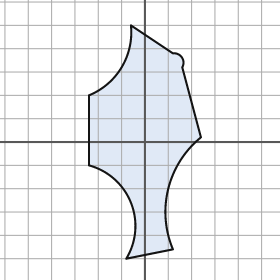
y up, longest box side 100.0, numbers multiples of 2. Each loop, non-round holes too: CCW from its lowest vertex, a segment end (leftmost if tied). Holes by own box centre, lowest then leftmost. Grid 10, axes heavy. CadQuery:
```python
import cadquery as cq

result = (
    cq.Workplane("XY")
    .moveTo(-8.0, -50.0)
    .lineTo(12.0, -46.0)
    .threePointArc((10.0, -20.0), (24.0, 2.0))
    .lineTo(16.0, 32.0)
    .threePointArc((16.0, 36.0), (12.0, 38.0))
    .lineTo(-6.0, 50.0)
    .threePointArc((-10.0, 32.0), (-24.0, 20.0))
    .lineTo(-24.0, -10.0)
    .threePointArc((-6.0, -26.0), (-8.0, -50.0))
    .close()
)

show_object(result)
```